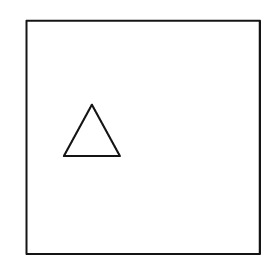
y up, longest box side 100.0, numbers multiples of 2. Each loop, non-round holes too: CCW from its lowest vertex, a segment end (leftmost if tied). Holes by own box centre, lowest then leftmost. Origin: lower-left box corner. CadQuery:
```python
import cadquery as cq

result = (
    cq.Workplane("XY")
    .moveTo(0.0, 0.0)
    .lineTo(100.0, 0.0)
    .lineTo(100.0, 100.0)
    .lineTo(0.0, 100.0)
    .close()
    .moveTo(16.0, 42.0)
    .lineTo(40.0, 42.0)
    .lineTo(28.0, 64.0)
    .close()
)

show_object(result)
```